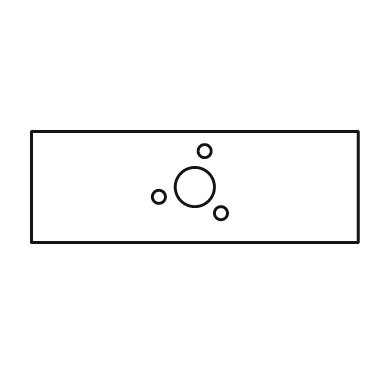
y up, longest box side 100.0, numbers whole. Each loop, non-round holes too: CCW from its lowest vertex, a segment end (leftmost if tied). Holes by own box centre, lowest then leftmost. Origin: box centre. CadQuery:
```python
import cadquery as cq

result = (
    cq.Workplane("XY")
    .moveTo(-50.0, -17.0)
    .lineTo(50.0, -17.0)
    .lineTo(50.0, 17.0)
    .lineTo(-50.0, 17.0)
    .close()
    .moveTo(8.0, -8.0)
    .circle(2.0)
    .moveTo(-11.0, -3.0)
    .circle(2.0)
    .moveTo(0.0, 0.0)
    .circle(6.0)
    .moveTo(3.0, 11.0)
    .circle(2.0)
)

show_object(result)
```